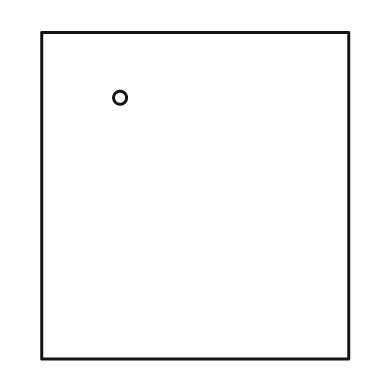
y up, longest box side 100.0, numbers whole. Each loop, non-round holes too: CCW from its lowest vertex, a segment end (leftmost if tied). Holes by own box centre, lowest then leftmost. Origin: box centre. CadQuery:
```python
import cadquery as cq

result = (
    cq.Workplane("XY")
    .moveTo(-47.0, -50.0)
    .lineTo(47.0, -50.0)
    .lineTo(47.0, 50.0)
    .lineTo(-47.0, 50.0)
    .close()
    .moveTo(-23.0, 30.0)
    .circle(2.0)
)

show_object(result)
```